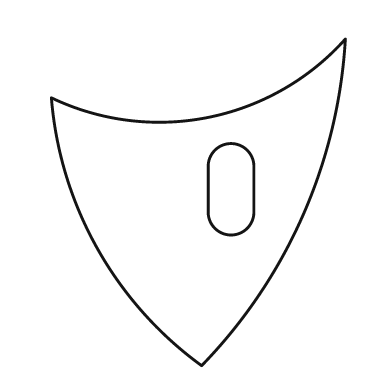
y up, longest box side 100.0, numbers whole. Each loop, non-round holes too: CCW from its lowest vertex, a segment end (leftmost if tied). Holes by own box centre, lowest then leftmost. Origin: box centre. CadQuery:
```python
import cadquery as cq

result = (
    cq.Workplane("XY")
    .moveTo(1.0, -50.0)
    .threePointArc((32.0, -4.0), (45.0, 50.0))
    .threePointArc((3.0, 26.0), (-45.0, 32.0))
    .threePointArc((-31.0, -14.0), (1.0, -50.0))
    .close()
    .moveTo(3.0, -3.0)
    .threePointArc((10.0, -10.0), (17.0, -3.0))
    .lineTo(17.0, 11.0)
    .threePointArc((10.0, 18.0), (3.0, 11.0))
    .close()
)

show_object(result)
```